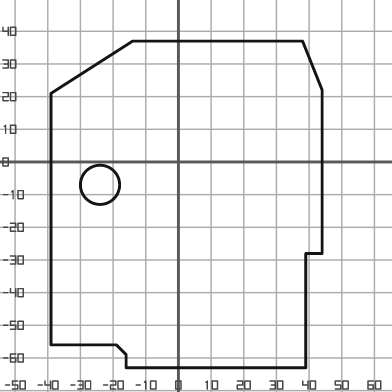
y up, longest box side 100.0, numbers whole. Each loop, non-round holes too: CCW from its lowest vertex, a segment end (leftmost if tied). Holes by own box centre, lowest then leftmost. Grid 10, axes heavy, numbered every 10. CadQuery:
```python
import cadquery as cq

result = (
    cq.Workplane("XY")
    .moveTo(-16.0, -63.0)
    .lineTo(39.0, -63.0)
    .lineTo(39.0, -28.0)
    .lineTo(44.0, -28.0)
    .lineTo(44.0, 22.0)
    .lineTo(38.0, 37.0)
    .lineTo(-14.0, 37.0)
    .lineTo(-39.0, 21.0)
    .lineTo(-39.0, -56.0)
    .lineTo(-19.0, -56.0)
    .lineTo(-16.0, -59.0)
    .close()
    .moveTo(-24.0, -7.0)
    .circle(6.0)
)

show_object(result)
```